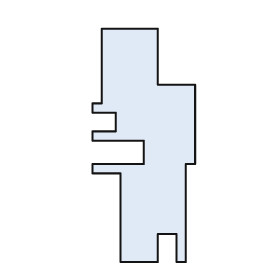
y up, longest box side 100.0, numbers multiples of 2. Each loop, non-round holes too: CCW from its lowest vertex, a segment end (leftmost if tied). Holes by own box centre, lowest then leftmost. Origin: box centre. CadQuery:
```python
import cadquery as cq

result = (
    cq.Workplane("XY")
    .moveTo(-10.0, -50.0)
    .lineTo(6.0, -50.0)
    .lineTo(6.0, -38.0)
    .lineTo(14.0, -38.0)
    .lineTo(14.0, -50.0)
    .lineTo(18.0, -50.0)
    .lineTo(18.0, -8.0)
    .lineTo(22.0, -8.0)
    .lineTo(22.0, 26.0)
    .lineTo(6.0, 26.0)
    .lineTo(6.0, 50.0)
    .lineTo(-18.0, 50.0)
    .lineTo(-18.0, 18.0)
    .lineTo(-22.0, 18.0)
    .lineTo(-22.0, 14.0)
    .lineTo(-12.0, 14.0)
    .lineTo(-12.0, 6.0)
    .lineTo(-22.0, 6.0)
    .lineTo(-22.0, 2.0)
    .lineTo(0.0, 2.0)
    .lineTo(0.0, -8.0)
    .lineTo(-22.0, -8.0)
    .lineTo(-22.0, -12.0)
    .lineTo(-10.0, -12.0)
    .close()
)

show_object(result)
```